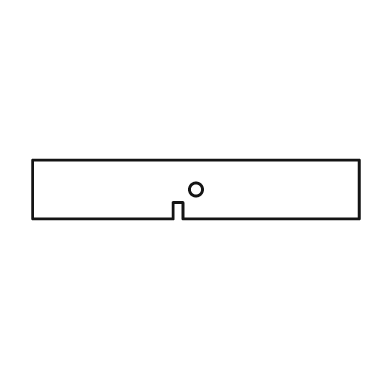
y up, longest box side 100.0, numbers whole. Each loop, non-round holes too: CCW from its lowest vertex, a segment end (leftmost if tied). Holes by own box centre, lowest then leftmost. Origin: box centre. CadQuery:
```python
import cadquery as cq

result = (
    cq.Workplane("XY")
    .moveTo(-50.0, -9.0)
    .lineTo(-7.0, -9.0)
    .lineTo(-7.0, -4.0)
    .lineTo(-4.0, -4.0)
    .lineTo(-4.0, -9.0)
    .lineTo(50.0, -9.0)
    .lineTo(50.0, 9.0)
    .lineTo(-50.0, 9.0)
    .close()
    .moveTo(0.0, 0.0)
    .circle(2.0)
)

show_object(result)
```